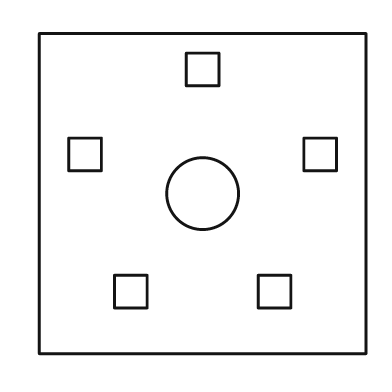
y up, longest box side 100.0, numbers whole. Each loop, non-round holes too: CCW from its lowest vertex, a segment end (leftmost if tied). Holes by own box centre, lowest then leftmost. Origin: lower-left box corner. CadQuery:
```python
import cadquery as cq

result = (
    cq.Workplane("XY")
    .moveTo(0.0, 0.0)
    .lineTo(100.0, 0.0)
    .lineTo(100.0, 98.0)
    .lineTo(0.0, 98.0)
    .close()
    .moveTo(23.0, 14.0)
    .lineTo(33.0, 14.0)
    .lineTo(33.0, 24.0)
    .lineTo(23.0, 24.0)
    .close()
    .moveTo(67.0, 14.0)
    .lineTo(77.0, 14.0)
    .lineTo(77.0, 24.0)
    .lineTo(67.0, 24.0)
    .close()
    .moveTo(50.0, 49.0)
    .circle(11.0)
    .moveTo(9.0, 56.0)
    .lineTo(19.0, 56.0)
    .lineTo(19.0, 66.0)
    .lineTo(9.0, 66.0)
    .close()
    .moveTo(81.0, 56.0)
    .lineTo(91.0, 56.0)
    .lineTo(91.0, 66.0)
    .lineTo(81.0, 66.0)
    .close()
    .moveTo(45.0, 82.0)
    .lineTo(55.0, 82.0)
    .lineTo(55.0, 92.0)
    .lineTo(45.0, 92.0)
    .close()
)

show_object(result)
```